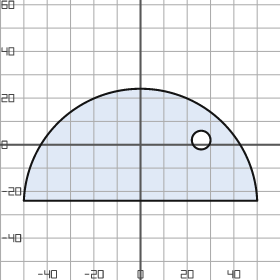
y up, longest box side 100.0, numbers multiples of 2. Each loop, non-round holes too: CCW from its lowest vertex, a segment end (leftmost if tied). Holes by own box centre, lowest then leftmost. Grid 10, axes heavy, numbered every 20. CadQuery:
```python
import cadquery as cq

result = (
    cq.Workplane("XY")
    .moveTo(-50.0, -24.0)
    .lineTo(50.0, -24.0)
    .threePointArc((0.0, 24.0), (-50.0, -24.0))
    .close()
    .moveTo(26.0, 2.0)
    .circle(4.0)
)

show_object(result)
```